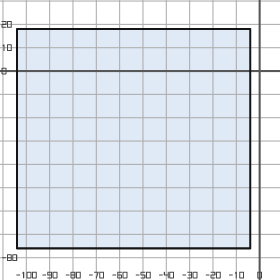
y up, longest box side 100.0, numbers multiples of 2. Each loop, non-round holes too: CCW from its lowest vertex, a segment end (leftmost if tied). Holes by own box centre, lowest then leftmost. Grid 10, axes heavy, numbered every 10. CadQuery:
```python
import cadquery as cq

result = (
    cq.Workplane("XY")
    .moveTo(-104.0, -76.0)
    .lineTo(-4.0, -76.0)
    .lineTo(-4.0, 18.0)
    .lineTo(-104.0, 18.0)
    .close()
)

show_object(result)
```